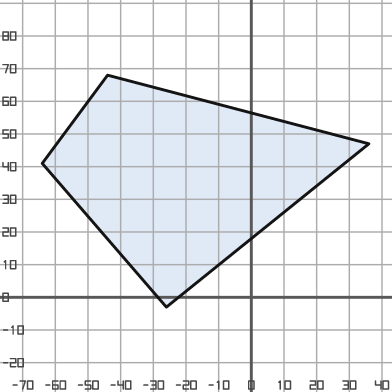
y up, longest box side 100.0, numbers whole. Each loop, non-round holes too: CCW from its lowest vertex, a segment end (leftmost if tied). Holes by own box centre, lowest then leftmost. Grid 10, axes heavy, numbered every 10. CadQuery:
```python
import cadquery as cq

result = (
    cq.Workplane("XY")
    .moveTo(-26.0, -3.0)
    .lineTo(36.0, 47.0)
    .lineTo(-44.0, 68.0)
    .lineTo(-64.0, 41.0)
    .close()
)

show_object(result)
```